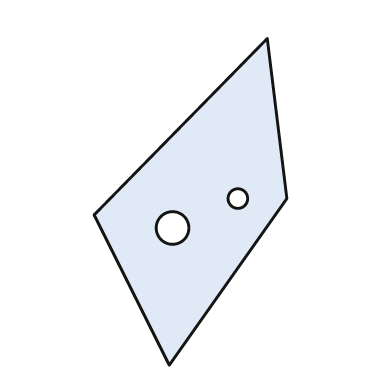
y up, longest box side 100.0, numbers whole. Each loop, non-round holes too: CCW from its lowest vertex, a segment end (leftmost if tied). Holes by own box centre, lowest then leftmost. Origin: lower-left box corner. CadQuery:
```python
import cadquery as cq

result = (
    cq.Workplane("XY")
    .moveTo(23.0, 0.0)
    .lineTo(59.0, 51.0)
    .lineTo(53.0, 100.0)
    .lineTo(0.0, 46.0)
    .close()
    .moveTo(24.0, 42.0)
    .circle(5.0)
    .moveTo(44.0, 51.0)
    .circle(3.0)
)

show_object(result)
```